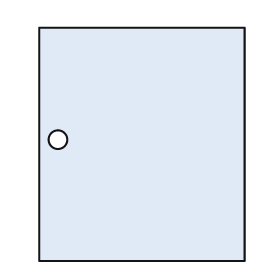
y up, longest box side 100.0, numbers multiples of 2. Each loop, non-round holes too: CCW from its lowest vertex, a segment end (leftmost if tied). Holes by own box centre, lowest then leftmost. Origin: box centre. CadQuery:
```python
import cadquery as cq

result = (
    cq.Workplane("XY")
    .moveTo(-44.0, -50.0)
    .lineTo(44.0, -50.0)
    .lineTo(44.0, 50.0)
    .lineTo(-44.0, 50.0)
    .close()
    .moveTo(-36.0, 2.0)
    .circle(4.0)
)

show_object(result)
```